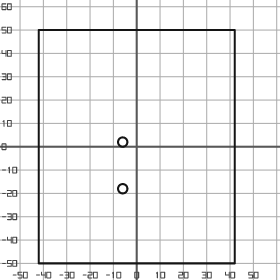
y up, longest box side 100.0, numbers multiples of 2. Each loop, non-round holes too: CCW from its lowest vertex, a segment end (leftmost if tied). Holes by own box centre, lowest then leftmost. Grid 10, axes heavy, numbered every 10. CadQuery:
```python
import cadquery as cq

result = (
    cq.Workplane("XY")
    .moveTo(-42.0, -50.0)
    .lineTo(42.0, -50.0)
    .lineTo(42.0, 50.0)
    .lineTo(-42.0, 50.0)
    .close()
    .moveTo(-6.0, -18.0)
    .circle(2.0)
    .moveTo(-6.0, 2.0)
    .circle(2.0)
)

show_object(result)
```